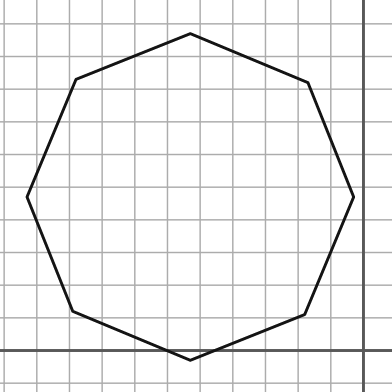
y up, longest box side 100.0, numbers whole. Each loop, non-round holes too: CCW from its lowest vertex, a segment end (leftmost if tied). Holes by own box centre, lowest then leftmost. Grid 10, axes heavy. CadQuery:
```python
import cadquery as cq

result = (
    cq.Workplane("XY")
    .moveTo(-53.0, -3.0)
    .lineTo(-18.0, 11.0)
    .lineTo(-3.0, 47.0)
    .lineTo(-17.0, 82.0)
    .lineTo(-53.0, 97.0)
    .lineTo(-88.0, 83.0)
    .lineTo(-103.0, 47.0)
    .lineTo(-89.0, 12.0)
    .close()
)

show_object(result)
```